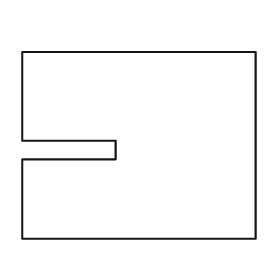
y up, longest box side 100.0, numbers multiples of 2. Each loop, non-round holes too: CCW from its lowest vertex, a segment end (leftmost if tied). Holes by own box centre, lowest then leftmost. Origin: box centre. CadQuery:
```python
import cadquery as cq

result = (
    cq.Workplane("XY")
    .moveTo(-50.0, -40.0)
    .lineTo(50.0, -40.0)
    .lineTo(50.0, 40.0)
    .lineTo(-50.0, 40.0)
    .lineTo(-50.0, 2.0)
    .lineTo(-10.0, 2.0)
    .lineTo(-10.0, -6.0)
    .lineTo(-50.0, -6.0)
    .close()
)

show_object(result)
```